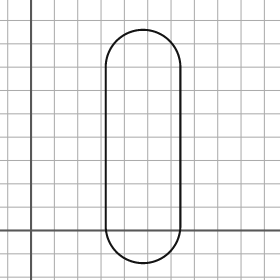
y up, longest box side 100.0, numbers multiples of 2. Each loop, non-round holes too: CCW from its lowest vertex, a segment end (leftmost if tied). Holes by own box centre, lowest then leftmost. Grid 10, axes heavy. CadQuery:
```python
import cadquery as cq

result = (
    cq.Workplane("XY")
    .moveTo(32.0, 2.0)
    .threePointArc((48.0, -14.0), (64.0, 2.0))
    .lineTo(64.0, 70.0)
    .threePointArc((48.0, 86.0), (32.0, 70.0))
    .close()
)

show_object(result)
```